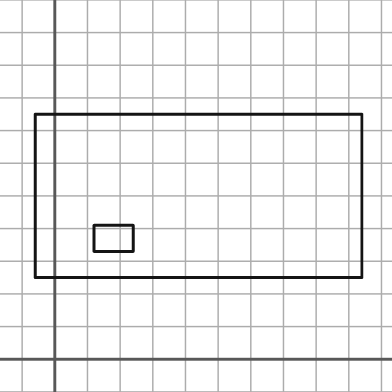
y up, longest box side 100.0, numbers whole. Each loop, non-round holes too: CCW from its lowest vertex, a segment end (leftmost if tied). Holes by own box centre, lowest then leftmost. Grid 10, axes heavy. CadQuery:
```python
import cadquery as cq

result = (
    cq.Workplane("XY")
    .moveTo(-6.0, 25.0)
    .lineTo(94.0, 25.0)
    .lineTo(94.0, 75.0)
    .lineTo(-6.0, 75.0)
    .close()
    .moveTo(12.0, 33.0)
    .lineTo(24.0, 33.0)
    .lineTo(24.0, 41.0)
    .lineTo(12.0, 41.0)
    .close()
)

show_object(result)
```